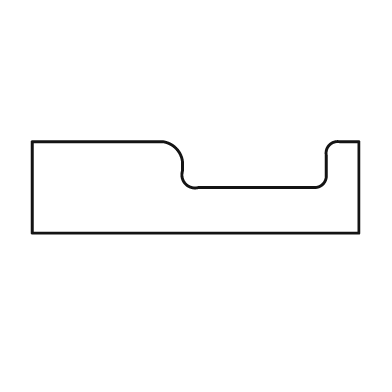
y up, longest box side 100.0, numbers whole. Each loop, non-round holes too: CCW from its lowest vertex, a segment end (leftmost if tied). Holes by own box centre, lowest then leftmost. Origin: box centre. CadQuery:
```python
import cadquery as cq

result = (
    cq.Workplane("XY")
    .moveTo(-50.0, -14.0)
    .lineTo(50.0, -14.0)
    .lineTo(50.0, 14.0)
    .lineTo(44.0, 14.0)
    .threePointArc((41.0, 13.0), (40.0, 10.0))
    .lineTo(40.0, 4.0)
    .threePointArc((39.0, 1.0), (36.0, 0.0))
    .lineTo(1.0, 0.0)
    .threePointArc((-3.0, 1.0), (-4.0, 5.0))
    .lineTo(-4.0, 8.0)
    .threePointArc((-6.0, 12.0), (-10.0, 14.0))
    .lineTo(-50.0, 14.0)
    .close()
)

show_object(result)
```